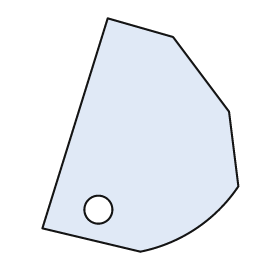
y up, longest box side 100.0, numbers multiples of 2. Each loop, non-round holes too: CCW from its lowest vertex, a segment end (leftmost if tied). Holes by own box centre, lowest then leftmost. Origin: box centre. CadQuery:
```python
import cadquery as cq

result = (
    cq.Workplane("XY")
    .moveTo(0.0, -50.0)
    .threePointArc((24.0, -40.0), (42.0, -22.0))
    .lineTo(38.0, 10.0)
    .lineTo(14.0, 42.0)
    .lineTo(-14.0, 50.0)
    .lineTo(-42.0, -40.0)
    .close()
    .moveTo(-18.0, -32.0)
    .circle(6.0)
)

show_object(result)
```